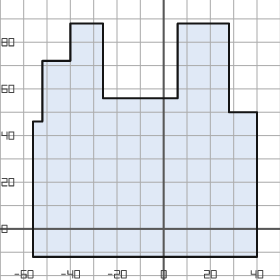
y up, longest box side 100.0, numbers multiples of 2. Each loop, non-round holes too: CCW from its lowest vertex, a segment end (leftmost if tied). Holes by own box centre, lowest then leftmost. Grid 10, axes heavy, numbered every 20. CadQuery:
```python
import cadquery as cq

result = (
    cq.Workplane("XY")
    .moveTo(-56.0, -12.0)
    .lineTo(40.0, -12.0)
    .lineTo(40.0, 50.0)
    .lineTo(28.0, 50.0)
    .lineTo(28.0, 88.0)
    .lineTo(6.0, 88.0)
    .lineTo(6.0, 56.0)
    .lineTo(-26.0, 56.0)
    .lineTo(-26.0, 88.0)
    .lineTo(-40.0, 88.0)
    .lineTo(-40.0, 72.0)
    .lineTo(-52.0, 72.0)
    .lineTo(-52.0, 46.0)
    .lineTo(-56.0, 46.0)
    .close()
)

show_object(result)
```